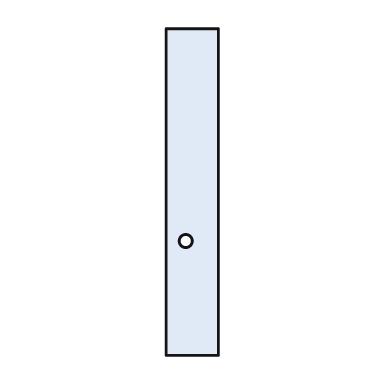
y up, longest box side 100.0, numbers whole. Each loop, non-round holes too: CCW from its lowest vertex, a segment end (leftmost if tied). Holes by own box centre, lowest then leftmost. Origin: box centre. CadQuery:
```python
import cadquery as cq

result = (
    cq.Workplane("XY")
    .moveTo(-8.0, -50.0)
    .lineTo(8.0, -50.0)
    .lineTo(8.0, 50.0)
    .lineTo(-8.0, 50.0)
    .close()
    .moveTo(-2.0, -15.0)
    .circle(2.0)
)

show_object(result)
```